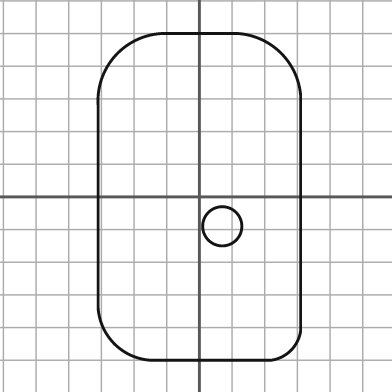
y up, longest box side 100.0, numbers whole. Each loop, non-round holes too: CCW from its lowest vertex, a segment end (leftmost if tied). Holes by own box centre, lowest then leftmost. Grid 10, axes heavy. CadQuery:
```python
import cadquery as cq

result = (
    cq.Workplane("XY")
    .moveTo(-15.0, -50.0)
    .lineTo(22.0, -50.0)
    .threePointArc((28.0, -47.0), (31.0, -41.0))
    .lineTo(31.0, 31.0)
    .threePointArc((25.0, 44.0), (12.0, 50.0))
    .lineTo(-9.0, 50.0)
    .threePointArc((-25.0, 44.0), (-31.0, 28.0))
    .lineTo(-31.0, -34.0)
    .threePointArc((-26.0, -45.0), (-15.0, -50.0))
    .close()
    .moveTo(7.0, -9.0)
    .circle(6.0)
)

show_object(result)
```